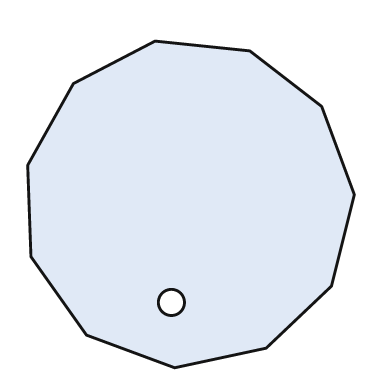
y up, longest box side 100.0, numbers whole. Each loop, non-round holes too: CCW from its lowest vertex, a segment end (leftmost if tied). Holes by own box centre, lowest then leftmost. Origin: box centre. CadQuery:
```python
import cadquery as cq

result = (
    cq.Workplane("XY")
    .moveTo(-5.0, -50.0)
    .lineTo(23.0, -44.0)
    .lineTo(43.0, -25.0)
    .lineTo(50.0, 3.0)
    .lineTo(40.0, 30.0)
    .lineTo(18.0, 47.0)
    .lineTo(-11.0, 50.0)
    .lineTo(-36.0, 37.0)
    .lineTo(-50.0, 12.0)
    .lineTo(-49.0, -16.0)
    .lineTo(-32.0, -40.0)
    .close()
    .moveTo(-6.0, -30.0)
    .circle(4.0)
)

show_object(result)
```